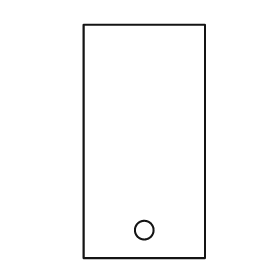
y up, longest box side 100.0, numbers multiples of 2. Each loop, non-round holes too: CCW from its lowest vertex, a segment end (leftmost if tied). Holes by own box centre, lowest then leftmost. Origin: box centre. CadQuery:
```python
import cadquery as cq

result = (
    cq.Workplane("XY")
    .moveTo(-26.0, -50.0)
    .lineTo(26.0, -50.0)
    .lineTo(26.0, 50.0)
    .lineTo(-26.0, 50.0)
    .close()
    .moveTo(0.0, -38.0)
    .circle(4.0)
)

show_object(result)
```